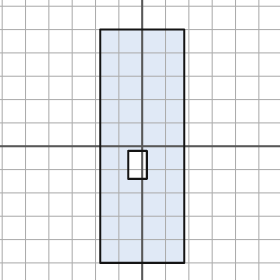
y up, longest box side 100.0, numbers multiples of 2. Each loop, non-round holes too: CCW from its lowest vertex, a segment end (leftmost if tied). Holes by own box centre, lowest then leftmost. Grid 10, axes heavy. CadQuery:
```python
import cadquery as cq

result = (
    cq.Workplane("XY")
    .moveTo(-18.0, -50.0)
    .lineTo(18.0, -50.0)
    .lineTo(18.0, 50.0)
    .lineTo(-18.0, 50.0)
    .close()
    .moveTo(-6.0, -14.0)
    .lineTo(2.0, -14.0)
    .lineTo(2.0, -2.0)
    .lineTo(-6.0, -2.0)
    .close()
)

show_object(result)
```